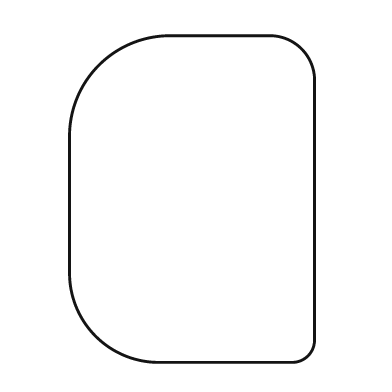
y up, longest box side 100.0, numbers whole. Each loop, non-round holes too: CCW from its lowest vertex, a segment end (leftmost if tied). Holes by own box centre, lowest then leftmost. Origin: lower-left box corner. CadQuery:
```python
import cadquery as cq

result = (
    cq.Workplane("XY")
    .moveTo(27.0, 0.0)
    .lineTo(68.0, 0.0)
    .threePointArc((73.0, 2.0), (75.0, 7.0))
    .lineTo(75.0, 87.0)
    .threePointArc((71.0, 96.0), (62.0, 100.0))
    .lineTo(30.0, 100.0)
    .threePointArc((9.0, 91.0), (0.0, 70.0))
    .lineTo(0.0, 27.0)
    .threePointArc((8.0, 8.0), (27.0, 0.0))
    .close()
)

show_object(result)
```